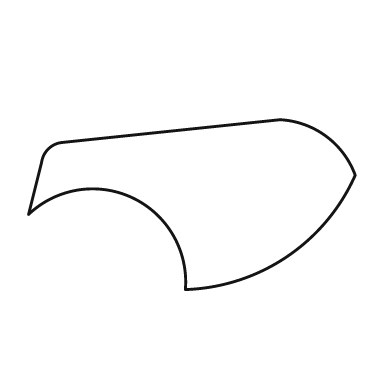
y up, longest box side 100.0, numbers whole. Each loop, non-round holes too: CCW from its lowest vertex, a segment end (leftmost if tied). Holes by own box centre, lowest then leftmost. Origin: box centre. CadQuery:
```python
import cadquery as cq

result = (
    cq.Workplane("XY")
    .moveTo(-2.0, -26.0)
    .threePointArc((29.0, -16.0), (50.0, 9.0))
    .threePointArc((41.0, 21.0), (27.0, 26.0))
    .lineTo(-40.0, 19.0)
    .threePointArc((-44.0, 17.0), (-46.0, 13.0))
    .lineTo(-50.0, -3.0)
    .threePointArc((-18.0, 2.0), (-2.0, -26.0))
    .close()
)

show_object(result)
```